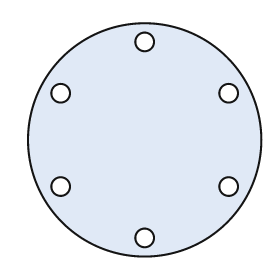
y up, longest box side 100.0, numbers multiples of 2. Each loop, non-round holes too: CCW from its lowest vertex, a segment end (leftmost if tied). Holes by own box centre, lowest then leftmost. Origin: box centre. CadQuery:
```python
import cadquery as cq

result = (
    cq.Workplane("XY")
    .moveTo(0.0, 0.0)
    .circle(50.0)
    .moveTo(0.0, -42.0)
    .circle(4.0)
    .moveTo(-36.0, -20.0)
    .circle(4.0)
    .moveTo(36.0, -20.0)
    .circle(4.0)
    .moveTo(-36.0, 20.0)
    .circle(4.0)
    .moveTo(36.0, 20.0)
    .circle(4.0)
    .moveTo(0.0, 42.0)
    .circle(4.0)
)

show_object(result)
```